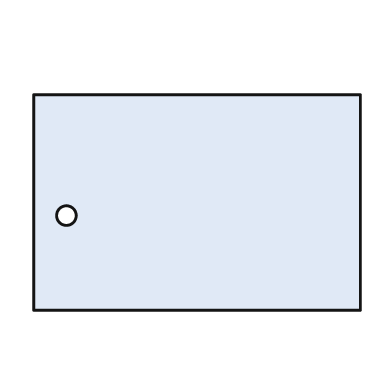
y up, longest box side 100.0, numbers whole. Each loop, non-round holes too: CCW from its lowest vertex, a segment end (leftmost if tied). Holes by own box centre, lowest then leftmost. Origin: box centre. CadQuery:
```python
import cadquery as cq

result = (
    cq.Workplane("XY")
    .moveTo(-50.0, -33.0)
    .lineTo(50.0, -33.0)
    .lineTo(50.0, 33.0)
    .lineTo(-50.0, 33.0)
    .close()
    .moveTo(-40.0, -4.0)
    .circle(3.0)
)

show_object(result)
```